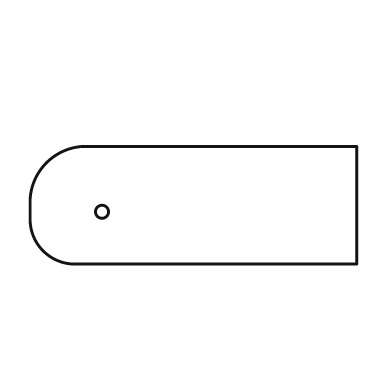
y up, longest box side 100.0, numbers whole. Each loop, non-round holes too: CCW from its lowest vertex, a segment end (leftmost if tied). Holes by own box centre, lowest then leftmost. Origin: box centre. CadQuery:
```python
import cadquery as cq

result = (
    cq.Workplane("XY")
    .moveTo(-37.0, -18.0)
    .lineTo(50.0, -18.0)
    .lineTo(50.0, 18.0)
    .lineTo(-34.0, 18.0)
    .threePointArc((-45.0, 13.0), (-50.0, 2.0))
    .lineTo(-50.0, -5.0)
    .threePointArc((-46.0, -14.0), (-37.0, -18.0))
    .close()
    .moveTo(-28.0, -2.0)
    .circle(2.0)
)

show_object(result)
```